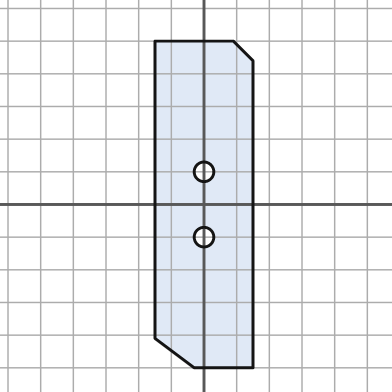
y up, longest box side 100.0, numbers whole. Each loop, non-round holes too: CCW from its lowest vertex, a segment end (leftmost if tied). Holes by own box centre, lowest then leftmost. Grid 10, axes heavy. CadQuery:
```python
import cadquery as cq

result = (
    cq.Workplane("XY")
    .moveTo(-3.0, -50.0)
    .lineTo(15.0, -50.0)
    .lineTo(15.0, 44.0)
    .lineTo(9.0, 50.0)
    .lineTo(-15.0, 50.0)
    .lineTo(-15.0, -41.0)
    .close()
    .moveTo(0.0, -10.0)
    .circle(3.0)
    .moveTo(0.0, 10.0)
    .circle(3.0)
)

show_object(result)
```